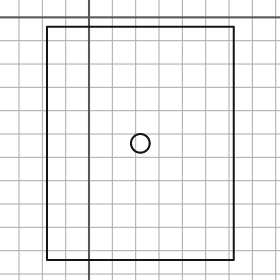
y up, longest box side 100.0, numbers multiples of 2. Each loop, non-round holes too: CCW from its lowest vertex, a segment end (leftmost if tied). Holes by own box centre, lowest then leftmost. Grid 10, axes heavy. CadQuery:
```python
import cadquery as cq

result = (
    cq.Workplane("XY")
    .moveTo(-18.0, -104.0)
    .lineTo(62.0, -104.0)
    .lineTo(62.0, -4.0)
    .lineTo(-18.0, -4.0)
    .close()
    .moveTo(22.0, -54.0)
    .circle(4.0)
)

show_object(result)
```